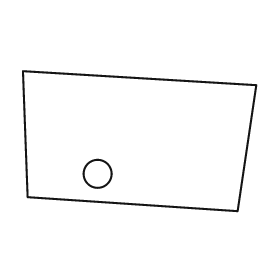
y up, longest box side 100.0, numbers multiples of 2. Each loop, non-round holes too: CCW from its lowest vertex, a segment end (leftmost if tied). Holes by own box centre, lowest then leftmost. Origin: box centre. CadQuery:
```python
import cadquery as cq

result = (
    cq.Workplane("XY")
    .moveTo(42.0, -30.0)
    .lineTo(50.0, 24.0)
    .lineTo(-50.0, 30.0)
    .lineTo(-48.0, -24.0)
    .close()
    .moveTo(-18.0, -14.0)
    .circle(6.0)
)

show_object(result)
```